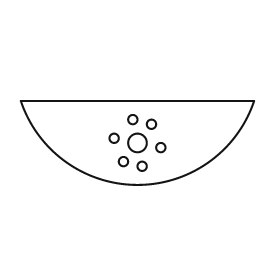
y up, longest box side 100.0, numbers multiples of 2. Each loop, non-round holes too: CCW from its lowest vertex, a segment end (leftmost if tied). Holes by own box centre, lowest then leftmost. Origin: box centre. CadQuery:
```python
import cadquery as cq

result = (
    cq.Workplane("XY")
    .moveTo(-50.0, 18.0)
    .threePointArc((0.0, -18.0), (50.0, 18.0))
    .close()
    .moveTo(2.0, -10.0)
    .circle(2.0)
    .moveTo(-6.0, -8.0)
    .circle(2.0)
    .moveTo(10.0, -2.0)
    .circle(2.0)
    .moveTo(0.0, 0.0)
    .circle(4.0)
    .moveTo(-10.0, 2.0)
    .circle(2.0)
    .moveTo(6.0, 8.0)
    .circle(2.0)
    .moveTo(-2.0, 10.0)
    .circle(2.0)
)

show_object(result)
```